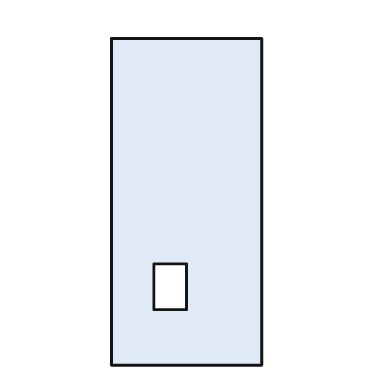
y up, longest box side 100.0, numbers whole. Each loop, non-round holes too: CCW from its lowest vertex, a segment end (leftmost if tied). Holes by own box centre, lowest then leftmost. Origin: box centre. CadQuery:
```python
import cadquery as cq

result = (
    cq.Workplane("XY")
    .moveTo(-23.0, -50.0)
    .lineTo(23.0, -50.0)
    .lineTo(23.0, 50.0)
    .lineTo(-23.0, 50.0)
    .close()
    .moveTo(-10.0, -33.0)
    .lineTo(0.0, -33.0)
    .lineTo(0.0, -19.0)
    .lineTo(-10.0, -19.0)
    .close()
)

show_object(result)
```